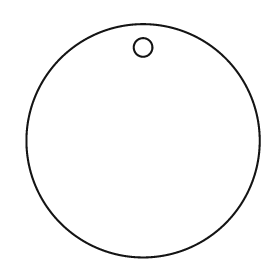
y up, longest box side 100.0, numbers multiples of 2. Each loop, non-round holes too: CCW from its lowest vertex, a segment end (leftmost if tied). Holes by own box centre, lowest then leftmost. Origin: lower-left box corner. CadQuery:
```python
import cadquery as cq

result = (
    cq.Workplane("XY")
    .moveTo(50.0, 50.0)
    .circle(50.0)
    .moveTo(50.0, 90.0)
    .circle(4.0)
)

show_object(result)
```